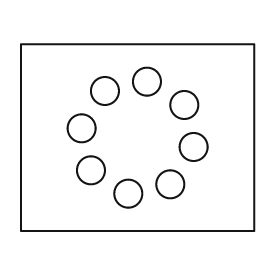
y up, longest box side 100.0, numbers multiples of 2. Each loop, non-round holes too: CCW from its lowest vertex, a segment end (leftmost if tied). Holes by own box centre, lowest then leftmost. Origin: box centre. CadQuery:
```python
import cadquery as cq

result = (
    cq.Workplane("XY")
    .moveTo(-50.0, -40.0)
    .lineTo(50.0, -40.0)
    .lineTo(50.0, 40.0)
    .lineTo(-50.0, 40.0)
    .close()
    .moveTo(-4.0, -24.0)
    .circle(6.0)
    .moveTo(14.0, -20.0)
    .circle(6.0)
    .moveTo(-20.0, -14.0)
    .circle(6.0)
    .moveTo(24.0, -4.0)
    .circle(6.0)
    .moveTo(-24.0, 4.0)
    .circle(6.0)
    .moveTo(20.0, 14.0)
    .circle(6.0)
    .moveTo(-14.0, 20.0)
    .circle(6.0)
    .moveTo(4.0, 24.0)
    .circle(6.0)
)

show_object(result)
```